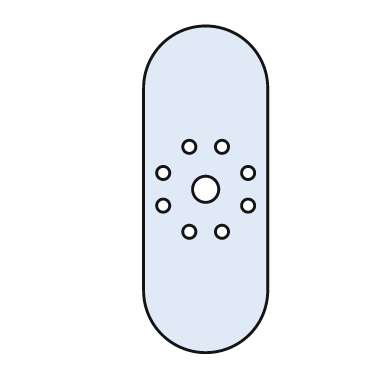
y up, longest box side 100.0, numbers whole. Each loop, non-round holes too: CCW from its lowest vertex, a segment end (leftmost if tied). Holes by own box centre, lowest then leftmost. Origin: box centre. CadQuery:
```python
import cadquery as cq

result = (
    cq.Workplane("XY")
    .moveTo(-19.0, -31.0)
    .threePointArc((0.0, -50.0), (19.0, -31.0))
    .lineTo(19.0, 31.0)
    .threePointArc((0.0, 50.0), (-19.0, 31.0))
    .close()
    .moveTo(-5.0, -13.0)
    .circle(2.0)
    .moveTo(5.0, -13.0)
    .circle(2.0)
    .moveTo(-13.0, -5.0)
    .circle(2.0)
    .moveTo(13.0, -5.0)
    .circle(2.0)
    .moveTo(0.0, 0.0)
    .circle(4.0)
    .moveTo(-13.0, 5.0)
    .circle(2.0)
    .moveTo(13.0, 5.0)
    .circle(2.0)
    .moveTo(-5.0, 13.0)
    .circle(2.0)
    .moveTo(5.0, 13.0)
    .circle(2.0)
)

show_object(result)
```